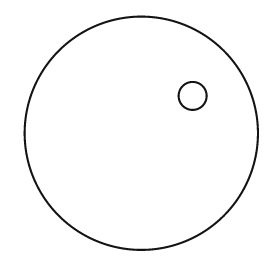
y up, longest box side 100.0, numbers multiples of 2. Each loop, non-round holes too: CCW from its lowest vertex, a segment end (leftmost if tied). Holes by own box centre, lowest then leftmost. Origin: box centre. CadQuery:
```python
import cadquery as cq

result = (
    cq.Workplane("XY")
    .moveTo(0.0, 0.0)
    .circle(50.0)
    .moveTo(22.0, 16.0)
    .circle(6.0)
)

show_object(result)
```